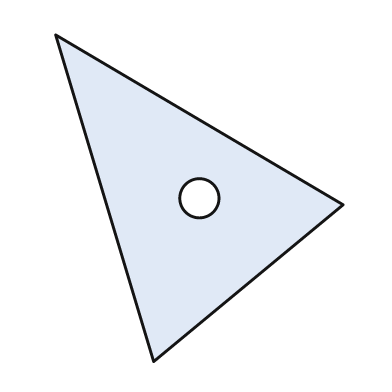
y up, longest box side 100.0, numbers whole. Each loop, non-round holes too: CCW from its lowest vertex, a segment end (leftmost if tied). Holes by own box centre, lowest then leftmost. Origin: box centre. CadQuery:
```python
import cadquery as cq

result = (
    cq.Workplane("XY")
    .moveTo(-14.0, -50.0)
    .lineTo(44.0, -2.0)
    .lineTo(-44.0, 50.0)
    .close()
    .moveTo(0.0, 0.0)
    .circle(6.0)
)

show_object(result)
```